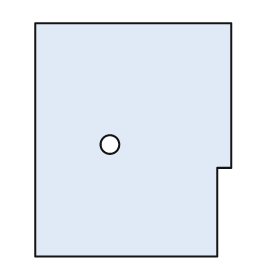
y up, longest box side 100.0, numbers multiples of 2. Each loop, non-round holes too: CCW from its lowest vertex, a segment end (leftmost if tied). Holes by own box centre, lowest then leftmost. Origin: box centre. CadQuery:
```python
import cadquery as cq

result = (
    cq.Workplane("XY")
    .moveTo(-42.0, -50.0)
    .lineTo(36.0, -50.0)
    .lineTo(36.0, -12.0)
    .lineTo(42.0, -12.0)
    .lineTo(42.0, 50.0)
    .lineTo(-42.0, 50.0)
    .close()
    .moveTo(-10.0, -2.0)
    .circle(4.0)
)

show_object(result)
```